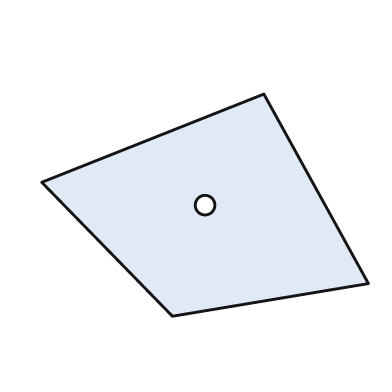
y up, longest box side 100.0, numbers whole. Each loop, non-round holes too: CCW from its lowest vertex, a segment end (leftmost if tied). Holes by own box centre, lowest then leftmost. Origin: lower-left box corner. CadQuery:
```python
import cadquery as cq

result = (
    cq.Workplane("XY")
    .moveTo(40.0, 0.0)
    .lineTo(100.0, 10.0)
    .lineTo(68.0, 68.0)
    .lineTo(0.0, 41.0)
    .close()
    .moveTo(50.0, 34.0)
    .circle(3.0)
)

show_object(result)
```